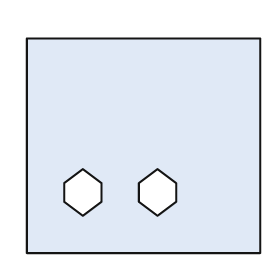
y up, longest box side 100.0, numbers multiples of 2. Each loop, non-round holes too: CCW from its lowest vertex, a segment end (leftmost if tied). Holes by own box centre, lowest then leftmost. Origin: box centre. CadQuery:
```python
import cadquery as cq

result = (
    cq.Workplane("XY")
    .moveTo(-50.0, -46.0)
    .lineTo(50.0, -46.0)
    .lineTo(50.0, 46.0)
    .lineTo(-50.0, 46.0)
    .close()
    .moveTo(-26.0, -30.0)
    .lineTo(-18.0, -24.0)
    .lineTo(-18.0, -16.0)
    .lineTo(-26.0, -10.0)
    .lineTo(-34.0, -16.0)
    .lineTo(-34.0, -24.0)
    .close()
    .moveTo(6.0, -30.0)
    .lineTo(14.0, -24.0)
    .lineTo(14.0, -16.0)
    .lineTo(6.0, -10.0)
    .lineTo(-2.0, -16.0)
    .lineTo(-2.0, -24.0)
    .close()
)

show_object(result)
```